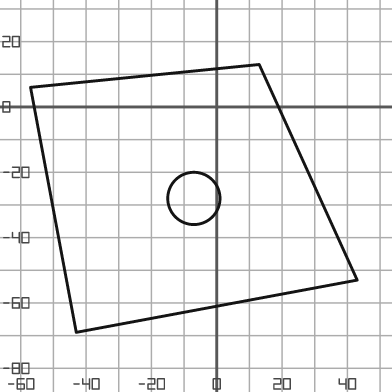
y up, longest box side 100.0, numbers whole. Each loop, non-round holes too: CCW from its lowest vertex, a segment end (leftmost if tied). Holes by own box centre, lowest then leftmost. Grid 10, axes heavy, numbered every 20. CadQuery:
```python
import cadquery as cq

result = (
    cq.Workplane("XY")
    .moveTo(-43.0, -69.0)
    .lineTo(43.0, -53.0)
    .lineTo(13.0, 13.0)
    .lineTo(-57.0, 6.0)
    .close()
    .moveTo(-7.0, -28.0)
    .circle(8.0)
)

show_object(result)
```